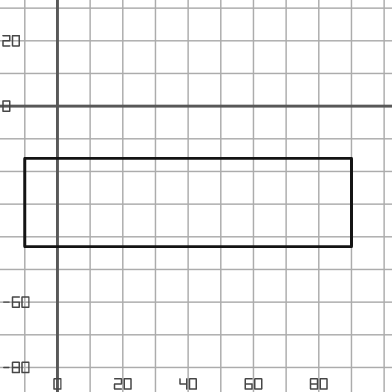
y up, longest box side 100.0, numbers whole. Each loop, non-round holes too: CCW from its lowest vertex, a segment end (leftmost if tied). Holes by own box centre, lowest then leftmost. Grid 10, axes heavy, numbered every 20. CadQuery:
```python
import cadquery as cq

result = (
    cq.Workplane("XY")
    .moveTo(-10.0, -43.0)
    .lineTo(90.0, -43.0)
    .lineTo(90.0, -16.0)
    .lineTo(-10.0, -16.0)
    .close()
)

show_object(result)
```